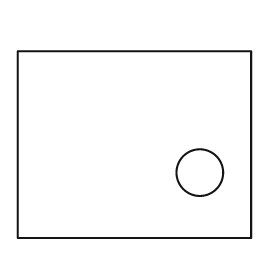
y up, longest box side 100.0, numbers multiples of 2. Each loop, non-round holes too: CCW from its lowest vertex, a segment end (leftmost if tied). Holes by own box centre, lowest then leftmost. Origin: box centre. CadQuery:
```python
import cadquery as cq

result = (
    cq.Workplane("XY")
    .moveTo(-50.0, -40.0)
    .lineTo(50.0, -40.0)
    .lineTo(50.0, 40.0)
    .lineTo(-50.0, 40.0)
    .close()
    .moveTo(28.0, -12.0)
    .circle(10.0)
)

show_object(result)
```